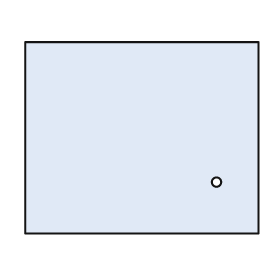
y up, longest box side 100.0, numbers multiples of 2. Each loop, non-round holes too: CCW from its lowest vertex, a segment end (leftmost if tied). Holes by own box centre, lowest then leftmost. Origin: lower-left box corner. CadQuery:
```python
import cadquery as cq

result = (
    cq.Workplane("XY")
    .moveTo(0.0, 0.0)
    .lineTo(100.0, 0.0)
    .lineTo(100.0, 82.0)
    .lineTo(0.0, 82.0)
    .close()
    .moveTo(82.0, 22.0)
    .circle(2.0)
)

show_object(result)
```